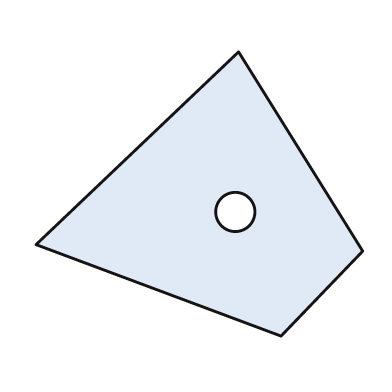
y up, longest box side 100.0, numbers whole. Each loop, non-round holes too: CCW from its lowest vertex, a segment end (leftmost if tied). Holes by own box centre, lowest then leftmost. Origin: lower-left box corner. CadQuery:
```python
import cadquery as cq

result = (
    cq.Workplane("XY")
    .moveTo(75.0, 0.0)
    .lineTo(100.0, 26.0)
    .lineTo(62.0, 87.0)
    .lineTo(0.0, 28.0)
    .close()
    .moveTo(61.0, 38.0)
    .circle(6.0)
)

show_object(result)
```